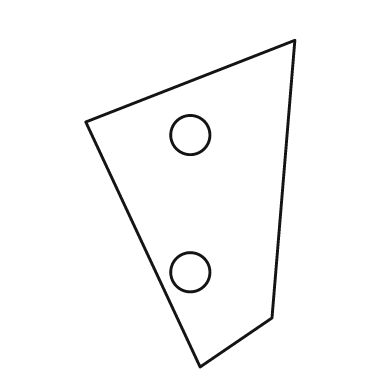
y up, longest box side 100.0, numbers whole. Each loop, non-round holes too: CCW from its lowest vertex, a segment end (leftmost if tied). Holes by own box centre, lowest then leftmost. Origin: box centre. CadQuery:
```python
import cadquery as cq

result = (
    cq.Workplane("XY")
    .moveTo(3.0, -50.0)
    .lineTo(25.0, -35.0)
    .lineTo(32.0, 50.0)
    .lineTo(-32.0, 25.0)
    .close()
    .moveTo(0.0, -21.0)
    .circle(6.0)
    .moveTo(0.0, 21.0)
    .circle(6.0)
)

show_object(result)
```